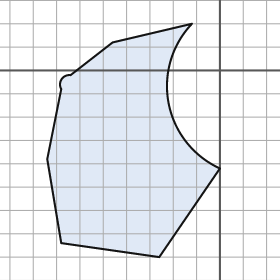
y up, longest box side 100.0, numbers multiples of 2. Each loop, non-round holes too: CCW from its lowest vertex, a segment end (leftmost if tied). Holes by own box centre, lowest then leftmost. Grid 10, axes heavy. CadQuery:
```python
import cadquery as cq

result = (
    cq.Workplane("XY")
    .moveTo(-26.0, -80.0)
    .lineTo(0.0, -42.0)
    .threePointArc((-22.0, -14.0), (-12.0, 20.0))
    .lineTo(-46.0, 12.0)
    .lineTo(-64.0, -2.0)
    .threePointArc((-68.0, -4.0), (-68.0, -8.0))
    .lineTo(-74.0, -38.0)
    .lineTo(-68.0, -74.0)
    .close()
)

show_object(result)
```